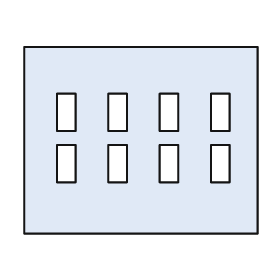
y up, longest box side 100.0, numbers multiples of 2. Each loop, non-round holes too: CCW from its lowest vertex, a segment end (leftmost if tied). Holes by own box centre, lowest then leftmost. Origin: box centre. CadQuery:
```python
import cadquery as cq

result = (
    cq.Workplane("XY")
    .moveTo(-50.0, -40.0)
    .lineTo(50.0, -40.0)
    .lineTo(50.0, 40.0)
    .lineTo(-50.0, 40.0)
    .close()
    .moveTo(-36.0, -18.0)
    .lineTo(-28.0, -18.0)
    .lineTo(-28.0, -2.0)
    .lineTo(-36.0, -2.0)
    .close()
    .moveTo(-14.0, -18.0)
    .lineTo(-6.0, -18.0)
    .lineTo(-6.0, -2.0)
    .lineTo(-14.0, -2.0)
    .close()
    .moveTo(8.0, -18.0)
    .lineTo(16.0, -18.0)
    .lineTo(16.0, -2.0)
    .lineTo(8.0, -2.0)
    .close()
    .moveTo(30.0, -18.0)
    .lineTo(38.0, -18.0)
    .lineTo(38.0, -2.0)
    .lineTo(30.0, -2.0)
    .close()
    .moveTo(-36.0, 4.0)
    .lineTo(-28.0, 4.0)
    .lineTo(-28.0, 20.0)
    .lineTo(-36.0, 20.0)
    .close()
    .moveTo(-14.0, 4.0)
    .lineTo(-6.0, 4.0)
    .lineTo(-6.0, 20.0)
    .lineTo(-14.0, 20.0)
    .close()
    .moveTo(8.0, 4.0)
    .lineTo(16.0, 4.0)
    .lineTo(16.0, 20.0)
    .lineTo(8.0, 20.0)
    .close()
    .moveTo(30.0, 4.0)
    .lineTo(38.0, 4.0)
    .lineTo(38.0, 20.0)
    .lineTo(30.0, 20.0)
    .close()
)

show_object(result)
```